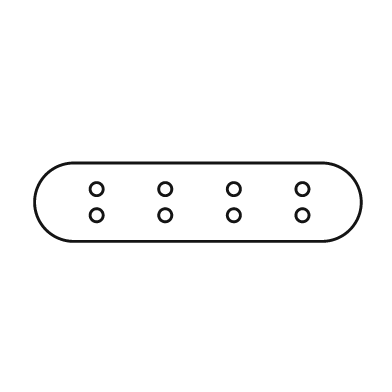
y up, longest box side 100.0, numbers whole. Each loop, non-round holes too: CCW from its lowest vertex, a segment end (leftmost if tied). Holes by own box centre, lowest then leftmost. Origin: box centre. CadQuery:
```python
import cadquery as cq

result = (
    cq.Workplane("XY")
    .moveTo(-38.0, -12.0)
    .lineTo(38.0, -12.0)
    .threePointArc((50.0, 0.0), (38.0, 12.0))
    .lineTo(-38.0, 12.0)
    .threePointArc((-50.0, 0.0), (-38.0, -12.0))
    .close()
    .moveTo(-31.0, -4.0)
    .circle(2.0)
    .moveTo(-10.0, -4.0)
    .circle(2.0)
    .moveTo(11.0, -4.0)
    .circle(2.0)
    .moveTo(32.0, -4.0)
    .circle(2.0)
    .moveTo(-31.0, 4.0)
    .circle(2.0)
    .moveTo(-10.0, 4.0)
    .circle(2.0)
    .moveTo(11.0, 4.0)
    .circle(2.0)
    .moveTo(32.0, 4.0)
    .circle(2.0)
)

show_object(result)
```